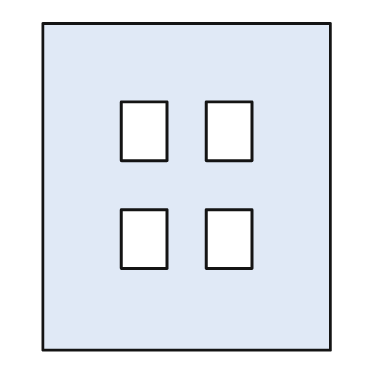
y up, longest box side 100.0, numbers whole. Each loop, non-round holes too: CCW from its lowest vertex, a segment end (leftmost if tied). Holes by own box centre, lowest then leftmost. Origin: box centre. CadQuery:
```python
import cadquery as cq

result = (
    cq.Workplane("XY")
    .moveTo(-44.0, -50.0)
    .lineTo(44.0, -50.0)
    .lineTo(44.0, 50.0)
    .lineTo(-44.0, 50.0)
    .close()
    .moveTo(-20.0, -25.0)
    .lineTo(-6.0, -25.0)
    .lineTo(-6.0, -7.0)
    .lineTo(-20.0, -7.0)
    .close()
    .moveTo(6.0, -25.0)
    .lineTo(20.0, -25.0)
    .lineTo(20.0, -7.0)
    .lineTo(6.0, -7.0)
    .close()
    .moveTo(-20.0, 8.0)
    .lineTo(-6.0, 8.0)
    .lineTo(-6.0, 26.0)
    .lineTo(-20.0, 26.0)
    .close()
    .moveTo(6.0, 8.0)
    .lineTo(20.0, 8.0)
    .lineTo(20.0, 26.0)
    .lineTo(6.0, 26.0)
    .close()
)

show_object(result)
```